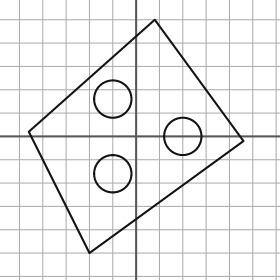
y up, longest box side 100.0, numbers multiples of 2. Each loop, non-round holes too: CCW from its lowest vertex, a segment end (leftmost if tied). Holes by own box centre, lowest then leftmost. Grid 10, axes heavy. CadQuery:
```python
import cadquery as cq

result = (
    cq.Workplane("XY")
    .moveTo(-20.0, -50.0)
    .lineTo(46.0, -2.0)
    .lineTo(8.0, 50.0)
    .lineTo(-46.0, 2.0)
    .close()
    .moveTo(-10.0, -16.0)
    .circle(8.0)
    .moveTo(20.0, 0.0)
    .circle(8.0)
    .moveTo(-10.0, 16.0)
    .circle(8.0)
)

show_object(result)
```